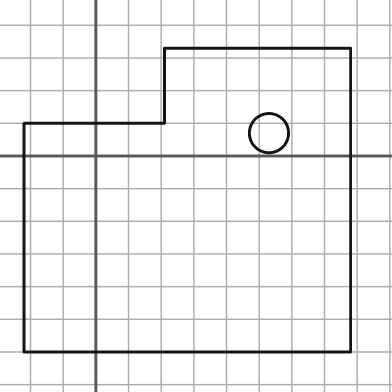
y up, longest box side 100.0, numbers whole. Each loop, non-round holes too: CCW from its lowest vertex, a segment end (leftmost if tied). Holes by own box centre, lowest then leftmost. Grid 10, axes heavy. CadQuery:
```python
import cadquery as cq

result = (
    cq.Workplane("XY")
    .moveTo(-22.0, -60.0)
    .lineTo(78.0, -60.0)
    .lineTo(78.0, 33.0)
    .lineTo(21.0, 33.0)
    .lineTo(21.0, 10.0)
    .lineTo(-22.0, 10.0)
    .close()
    .moveTo(53.0, 7.0)
    .circle(6.0)
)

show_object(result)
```